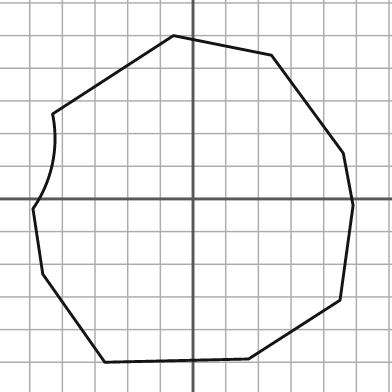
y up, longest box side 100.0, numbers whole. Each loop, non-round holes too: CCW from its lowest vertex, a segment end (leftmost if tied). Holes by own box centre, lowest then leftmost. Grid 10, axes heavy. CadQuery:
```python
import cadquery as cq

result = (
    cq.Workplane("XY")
    .moveTo(-27.0, -50.0)
    .lineTo(17.0, -49.0)
    .lineTo(45.0, -31.0)
    .lineTo(49.0, -2.0)
    .lineTo(46.0, 14.0)
    .lineTo(24.0, 44.0)
    .lineTo(-6.0, 50.0)
    .lineTo(-43.0, 26.0)
    .threePointArc((-43.0, 11.0), (-49.0, -3.0))
    .lineTo(-46.0, -23.0)
    .close()
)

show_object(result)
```